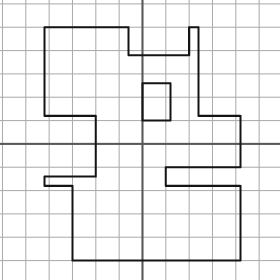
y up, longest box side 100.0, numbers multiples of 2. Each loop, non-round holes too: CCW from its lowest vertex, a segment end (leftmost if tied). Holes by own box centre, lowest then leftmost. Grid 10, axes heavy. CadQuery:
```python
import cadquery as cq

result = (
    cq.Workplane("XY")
    .moveTo(-30.0, -50.0)
    .lineTo(42.0, -50.0)
    .lineTo(42.0, -18.0)
    .lineTo(10.0, -18.0)
    .lineTo(10.0, -10.0)
    .lineTo(42.0, -10.0)
    .lineTo(42.0, 12.0)
    .lineTo(24.0, 12.0)
    .lineTo(24.0, 50.0)
    .lineTo(20.0, 50.0)
    .lineTo(20.0, 38.0)
    .lineTo(-6.0, 38.0)
    .lineTo(-6.0, 50.0)
    .lineTo(-42.0, 50.0)
    .lineTo(-42.0, 12.0)
    .lineTo(-20.0, 12.0)
    .lineTo(-20.0, -14.0)
    .lineTo(-42.0, -14.0)
    .lineTo(-42.0, -18.0)
    .lineTo(-30.0, -18.0)
    .close()
    .moveTo(0.0, 10.0)
    .lineTo(12.0, 10.0)
    .lineTo(12.0, 26.0)
    .lineTo(0.0, 26.0)
    .close()
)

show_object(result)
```